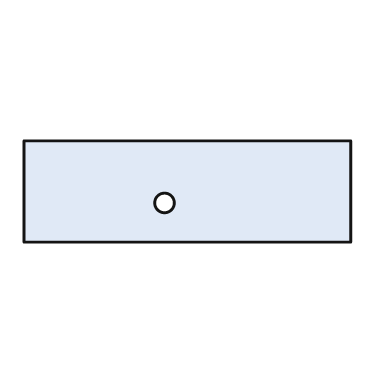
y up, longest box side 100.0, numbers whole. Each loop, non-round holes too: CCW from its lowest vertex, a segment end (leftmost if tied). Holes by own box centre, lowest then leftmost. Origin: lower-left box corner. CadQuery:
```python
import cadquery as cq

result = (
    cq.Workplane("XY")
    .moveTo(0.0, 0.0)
    .lineTo(100.0, 0.0)
    .lineTo(100.0, 31.0)
    .lineTo(0.0, 31.0)
    .close()
    .moveTo(43.0, 12.0)
    .circle(3.0)
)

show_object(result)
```